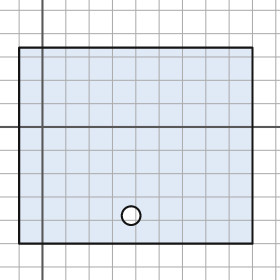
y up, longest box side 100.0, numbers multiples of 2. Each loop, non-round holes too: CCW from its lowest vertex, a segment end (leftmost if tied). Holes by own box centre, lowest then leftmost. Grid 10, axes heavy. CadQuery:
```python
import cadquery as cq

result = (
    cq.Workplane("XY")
    .moveTo(-10.0, -50.0)
    .lineTo(90.0, -50.0)
    .lineTo(90.0, 34.0)
    .lineTo(-10.0, 34.0)
    .close()
    .moveTo(38.0, -38.0)
    .circle(4.0)
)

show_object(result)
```